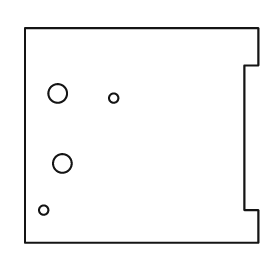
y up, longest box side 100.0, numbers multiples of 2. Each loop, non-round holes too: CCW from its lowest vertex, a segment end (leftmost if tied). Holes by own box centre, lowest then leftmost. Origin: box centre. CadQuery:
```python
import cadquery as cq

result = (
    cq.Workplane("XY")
    .moveTo(-50.0, -46.0)
    .lineTo(50.0, -46.0)
    .lineTo(50.0, -32.0)
    .lineTo(44.0, -32.0)
    .lineTo(44.0, 30.0)
    .lineTo(50.0, 30.0)
    .lineTo(50.0, 46.0)
    .lineTo(-50.0, 46.0)
    .close()
    .moveTo(-42.0, -32.0)
    .circle(2.0)
    .moveTo(-34.0, -12.0)
    .circle(4.0)
    .moveTo(-12.0, 16.0)
    .circle(2.0)
    .moveTo(-36.0, 18.0)
    .circle(4.0)
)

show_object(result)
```